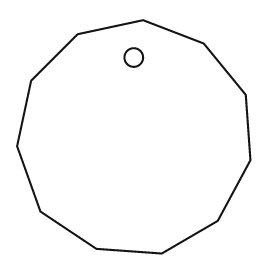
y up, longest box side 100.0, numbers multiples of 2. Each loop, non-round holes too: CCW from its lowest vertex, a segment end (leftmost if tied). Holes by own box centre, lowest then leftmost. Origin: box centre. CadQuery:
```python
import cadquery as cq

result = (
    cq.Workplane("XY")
    .moveTo(12.0, -50.0)
    .lineTo(36.0, -36.0)
    .lineTo(50.0, -10.0)
    .lineTo(48.0, 18.0)
    .lineTo(30.0, 40.0)
    .lineTo(4.0, 50.0)
    .lineTo(-24.0, 44.0)
    .lineTo(-44.0, 24.0)
    .lineTo(-50.0, -4.0)
    .lineTo(-40.0, -32.0)
    .lineTo(-16.0, -48.0)
    .close()
    .moveTo(0.0, 34.0)
    .circle(4.0)
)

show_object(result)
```